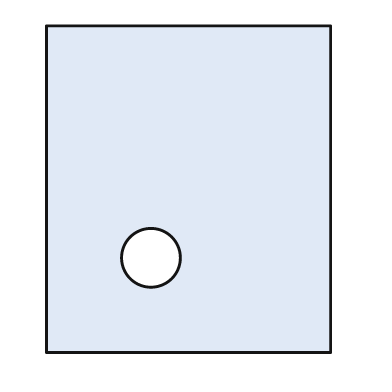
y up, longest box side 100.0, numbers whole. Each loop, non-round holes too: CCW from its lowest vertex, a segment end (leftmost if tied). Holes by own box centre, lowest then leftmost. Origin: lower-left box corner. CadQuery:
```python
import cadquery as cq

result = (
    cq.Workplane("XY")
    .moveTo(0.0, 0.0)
    .lineTo(87.0, 0.0)
    .lineTo(87.0, 100.0)
    .lineTo(0.0, 100.0)
    .close()
    .moveTo(32.0, 29.0)
    .circle(9.0)
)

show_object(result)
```